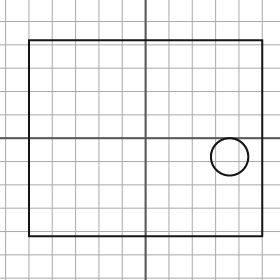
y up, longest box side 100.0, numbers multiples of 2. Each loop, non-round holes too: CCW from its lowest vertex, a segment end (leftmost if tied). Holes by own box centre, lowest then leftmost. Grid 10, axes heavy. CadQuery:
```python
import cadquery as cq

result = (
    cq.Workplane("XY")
    .moveTo(-50.0, -42.0)
    .lineTo(50.0, -42.0)
    .lineTo(50.0, 42.0)
    .lineTo(-50.0, 42.0)
    .close()
    .moveTo(36.0, -8.0)
    .circle(8.0)
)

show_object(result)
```